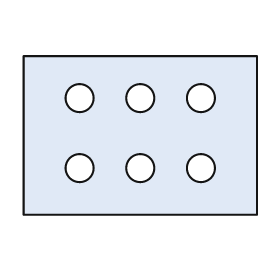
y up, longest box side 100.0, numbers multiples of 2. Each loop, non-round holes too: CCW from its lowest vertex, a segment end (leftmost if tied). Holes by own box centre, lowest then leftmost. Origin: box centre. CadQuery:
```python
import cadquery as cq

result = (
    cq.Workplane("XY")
    .moveTo(-50.0, -34.0)
    .lineTo(50.0, -34.0)
    .lineTo(50.0, 34.0)
    .lineTo(-50.0, 34.0)
    .close()
    .moveTo(-26.0, -14.0)
    .circle(6.0)
    .moveTo(0.0, -14.0)
    .circle(6.0)
    .moveTo(26.0, -14.0)
    .circle(6.0)
    .moveTo(-26.0, 16.0)
    .circle(6.0)
    .moveTo(0.0, 16.0)
    .circle(6.0)
    .moveTo(26.0, 16.0)
    .circle(6.0)
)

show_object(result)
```